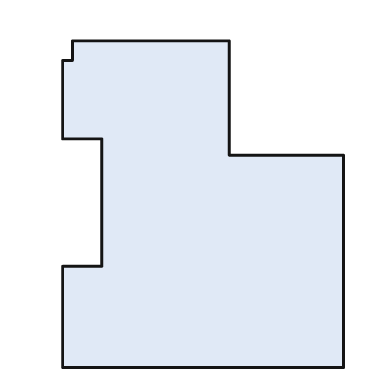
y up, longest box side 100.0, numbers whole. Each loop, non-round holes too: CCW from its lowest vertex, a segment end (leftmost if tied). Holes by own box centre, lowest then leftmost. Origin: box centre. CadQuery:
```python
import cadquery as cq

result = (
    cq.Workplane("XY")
    .moveTo(-43.0, -50.0)
    .lineTo(43.0, -50.0)
    .lineTo(43.0, 15.0)
    .lineTo(8.0, 15.0)
    .lineTo(8.0, 50.0)
    .lineTo(-40.0, 50.0)
    .lineTo(-40.0, 44.0)
    .lineTo(-43.0, 44.0)
    .lineTo(-43.0, 20.0)
    .lineTo(-31.0, 20.0)
    .lineTo(-31.0, -19.0)
    .lineTo(-43.0, -19.0)
    .close()
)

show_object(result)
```